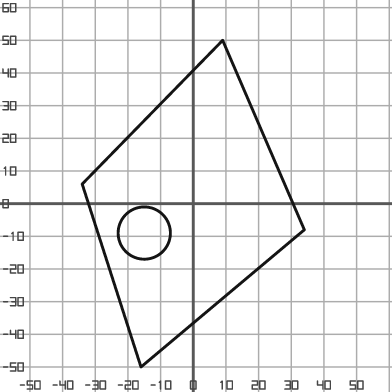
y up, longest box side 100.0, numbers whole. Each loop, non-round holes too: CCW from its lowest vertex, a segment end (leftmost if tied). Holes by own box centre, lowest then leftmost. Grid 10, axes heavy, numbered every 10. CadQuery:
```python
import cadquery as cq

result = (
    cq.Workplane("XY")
    .moveTo(-16.0, -50.0)
    .lineTo(34.0, -8.0)
    .lineTo(9.0, 50.0)
    .lineTo(-34.0, 6.0)
    .close()
    .moveTo(-15.0, -9.0)
    .circle(8.0)
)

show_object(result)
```